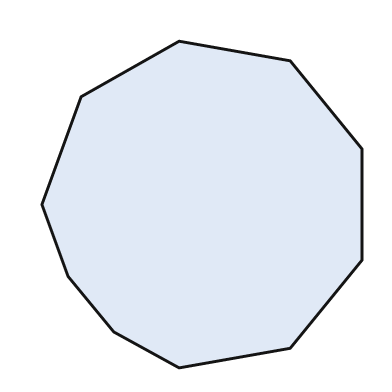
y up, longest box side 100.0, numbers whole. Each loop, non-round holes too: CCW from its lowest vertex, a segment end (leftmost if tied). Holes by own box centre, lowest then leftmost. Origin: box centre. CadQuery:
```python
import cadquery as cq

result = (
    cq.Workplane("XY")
    .moveTo(-7.0, -50.0)
    .lineTo(27.0, -44.0)
    .lineTo(49.0, -17.0)
    .lineTo(49.0, 17.0)
    .lineTo(27.0, 44.0)
    .lineTo(-7.0, 50.0)
    .lineTo(-37.0, 33.0)
    .lineTo(-49.0, 0.0)
    .lineTo(-41.0, -22.0)
    .lineTo(-27.0, -39.0)
    .close()
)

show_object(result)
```